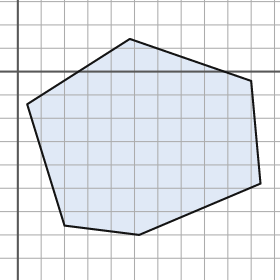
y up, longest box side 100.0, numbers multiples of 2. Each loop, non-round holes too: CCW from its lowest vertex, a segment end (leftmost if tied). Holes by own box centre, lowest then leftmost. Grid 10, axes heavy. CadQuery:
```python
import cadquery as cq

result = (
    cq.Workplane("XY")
    .moveTo(52.0, -70.0)
    .lineTo(104.0, -48.0)
    .lineTo(100.0, -4.0)
    .lineTo(48.0, 14.0)
    .lineTo(4.0, -14.0)
    .lineTo(20.0, -66.0)
    .close()
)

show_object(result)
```